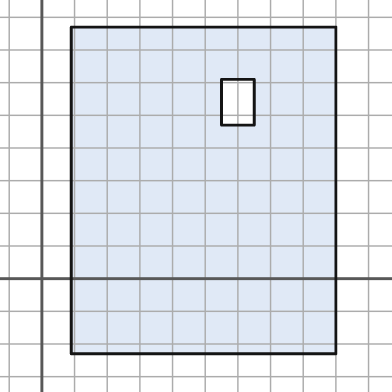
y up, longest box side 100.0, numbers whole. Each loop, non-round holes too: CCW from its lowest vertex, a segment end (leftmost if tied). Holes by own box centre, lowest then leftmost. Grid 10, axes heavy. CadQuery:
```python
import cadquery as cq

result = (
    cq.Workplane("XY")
    .moveTo(9.0, -23.0)
    .lineTo(90.0, -23.0)
    .lineTo(90.0, 77.0)
    .lineTo(9.0, 77.0)
    .close()
    .moveTo(55.0, 47.0)
    .lineTo(65.0, 47.0)
    .lineTo(65.0, 61.0)
    .lineTo(55.0, 61.0)
    .close()
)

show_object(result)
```